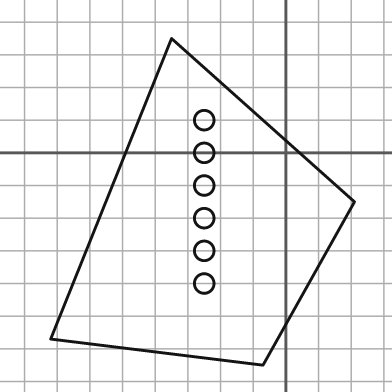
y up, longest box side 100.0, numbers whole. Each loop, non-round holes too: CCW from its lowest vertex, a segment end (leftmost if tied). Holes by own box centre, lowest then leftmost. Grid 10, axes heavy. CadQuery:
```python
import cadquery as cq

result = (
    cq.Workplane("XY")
    .moveTo(-7.0, -65.0)
    .lineTo(21.0, -15.0)
    .lineTo(-35.0, 35.0)
    .lineTo(-72.0, -57.0)
    .close()
    .moveTo(-25.0, -40.0)
    .circle(3.0)
    .moveTo(-25.0, -30.0)
    .circle(3.0)
    .moveTo(-25.0, -20.0)
    .circle(3.0)
    .moveTo(-25.0, -10.0)
    .circle(3.0)
    .moveTo(-25.0, 0.0)
    .circle(3.0)
    .moveTo(-25.0, 10.0)
    .circle(3.0)
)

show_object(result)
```